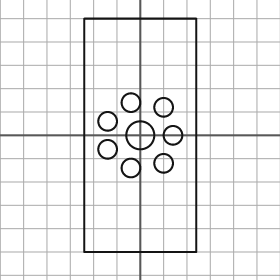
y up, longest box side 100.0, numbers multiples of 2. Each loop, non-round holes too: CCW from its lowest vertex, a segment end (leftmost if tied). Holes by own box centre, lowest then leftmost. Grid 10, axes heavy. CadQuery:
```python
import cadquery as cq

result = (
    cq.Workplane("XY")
    .moveTo(-24.0, -50.0)
    .lineTo(24.0, -50.0)
    .lineTo(24.0, 50.0)
    .lineTo(-24.0, 50.0)
    .close()
    .moveTo(-4.0, -14.0)
    .circle(4.0)
    .moveTo(10.0, -12.0)
    .circle(4.0)
    .moveTo(-14.0, -6.0)
    .circle(4.0)
    .moveTo(0.0, 0.0)
    .circle(6.0)
    .moveTo(14.0, 0.0)
    .circle(4.0)
    .moveTo(-14.0, 6.0)
    .circle(4.0)
    .moveTo(10.0, 12.0)
    .circle(4.0)
    .moveTo(-4.0, 14.0)
    .circle(4.0)
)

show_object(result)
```